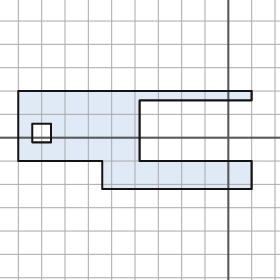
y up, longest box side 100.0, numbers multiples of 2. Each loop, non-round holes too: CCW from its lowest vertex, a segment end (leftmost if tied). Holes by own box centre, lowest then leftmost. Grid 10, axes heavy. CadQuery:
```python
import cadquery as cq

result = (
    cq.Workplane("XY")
    .moveTo(-54.0, -22.0)
    .lineTo(10.0, -22.0)
    .lineTo(10.0, -10.0)
    .lineTo(-38.0, -10.0)
    .lineTo(-38.0, 16.0)
    .lineTo(10.0, 16.0)
    .lineTo(10.0, 20.0)
    .lineTo(-90.0, 20.0)
    .lineTo(-90.0, -10.0)
    .lineTo(-54.0, -10.0)
    .close()
    .moveTo(-84.0, -2.0)
    .lineTo(-76.0, -2.0)
    .lineTo(-76.0, 6.0)
    .lineTo(-84.0, 6.0)
    .close()
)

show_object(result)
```